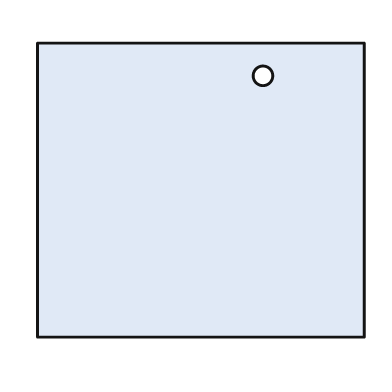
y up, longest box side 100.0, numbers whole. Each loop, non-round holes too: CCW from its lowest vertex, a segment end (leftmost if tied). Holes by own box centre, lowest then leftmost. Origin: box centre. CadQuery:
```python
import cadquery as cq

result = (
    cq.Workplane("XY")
    .moveTo(-50.0, -45.0)
    .lineTo(50.0, -45.0)
    .lineTo(50.0, 45.0)
    .lineTo(-50.0, 45.0)
    .close()
    .moveTo(19.0, 35.0)
    .circle(3.0)
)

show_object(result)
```